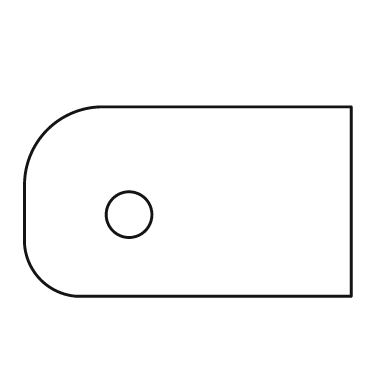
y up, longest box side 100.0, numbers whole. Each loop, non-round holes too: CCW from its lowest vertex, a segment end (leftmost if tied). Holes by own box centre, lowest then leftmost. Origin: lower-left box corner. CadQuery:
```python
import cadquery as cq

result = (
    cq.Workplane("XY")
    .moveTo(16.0, 0.0)
    .lineTo(100.0, 0.0)
    .lineTo(100.0, 58.0)
    .lineTo(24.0, 58.0)
    .threePointArc((7.0, 51.0), (0.0, 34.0))
    .lineTo(0.0, 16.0)
    .threePointArc((5.0, 5.0), (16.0, 0.0))
    .close()
    .moveTo(32.0, 25.0)
    .circle(7.0)
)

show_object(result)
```